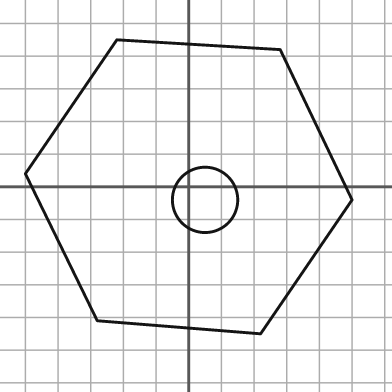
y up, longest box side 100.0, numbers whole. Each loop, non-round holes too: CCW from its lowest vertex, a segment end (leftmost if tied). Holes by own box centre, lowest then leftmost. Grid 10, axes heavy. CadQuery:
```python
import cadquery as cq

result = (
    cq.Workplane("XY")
    .moveTo(22.0, -45.0)
    .lineTo(50.0, -4.0)
    .lineTo(28.0, 42.0)
    .lineTo(-22.0, 45.0)
    .lineTo(-50.0, 4.0)
    .lineTo(-28.0, -41.0)
    .close()
    .moveTo(5.0, -4.0)
    .circle(10.0)
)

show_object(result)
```